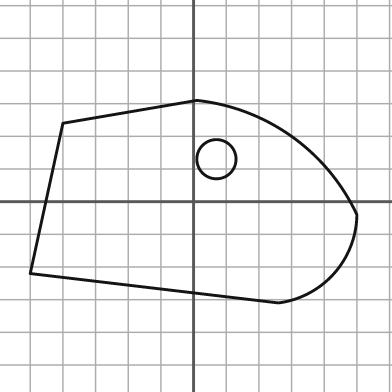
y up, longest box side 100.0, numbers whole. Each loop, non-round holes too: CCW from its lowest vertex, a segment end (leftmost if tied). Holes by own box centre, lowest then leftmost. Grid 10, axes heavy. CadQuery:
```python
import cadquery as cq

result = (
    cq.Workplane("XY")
    .moveTo(26.0, -31.0)
    .threePointArc((43.0, -22.0), (50.0, -4.0))
    .threePointArc((30.0, 20.0), (1.0, 31.0))
    .lineTo(-40.0, 24.0)
    .lineTo(-50.0, -22.0)
    .close()
    .moveTo(7.0, 13.0)
    .circle(6.0)
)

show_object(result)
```